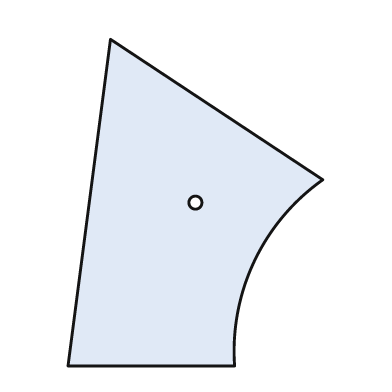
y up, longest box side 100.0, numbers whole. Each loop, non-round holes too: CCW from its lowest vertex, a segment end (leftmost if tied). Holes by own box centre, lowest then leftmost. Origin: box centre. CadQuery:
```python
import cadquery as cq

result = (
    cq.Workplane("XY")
    .moveTo(-39.0, -50.0)
    .lineTo(12.0, -50.0)
    .threePointArc((18.0, -18.0), (39.0, 7.0))
    .lineTo(-26.0, 50.0)
    .close()
    .moveTo(0.0, 0.0)
    .circle(2.0)
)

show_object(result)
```